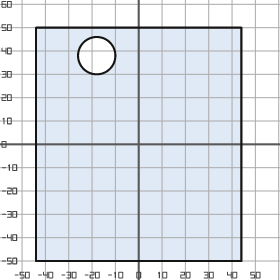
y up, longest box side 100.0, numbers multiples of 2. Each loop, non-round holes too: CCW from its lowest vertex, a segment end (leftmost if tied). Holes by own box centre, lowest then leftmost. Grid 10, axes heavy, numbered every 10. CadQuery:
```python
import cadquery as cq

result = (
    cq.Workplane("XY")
    .moveTo(-44.0, -50.0)
    .lineTo(44.0, -50.0)
    .lineTo(44.0, 50.0)
    .lineTo(-44.0, 50.0)
    .close()
    .moveTo(-18.0, 38.0)
    .circle(8.0)
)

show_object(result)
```